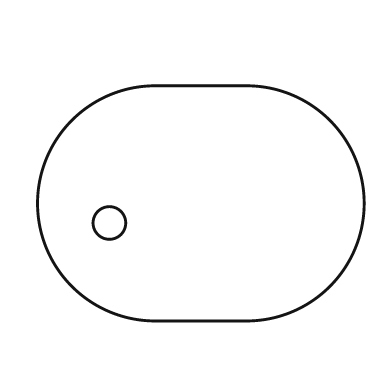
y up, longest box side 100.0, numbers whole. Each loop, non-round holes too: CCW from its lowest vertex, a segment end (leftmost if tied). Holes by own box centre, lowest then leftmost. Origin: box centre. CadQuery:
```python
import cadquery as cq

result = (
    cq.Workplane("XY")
    .moveTo(-14.0, -36.0)
    .lineTo(14.0, -36.0)
    .threePointArc((50.0, 0.0), (14.0, 36.0))
    .lineTo(-14.0, 36.0)
    .threePointArc((-50.0, 0.0), (-14.0, -36.0))
    .close()
    .moveTo(-28.0, -6.0)
    .circle(5.0)
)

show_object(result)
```